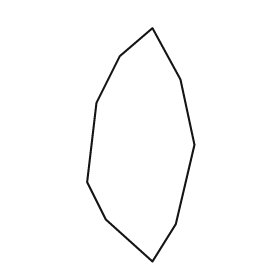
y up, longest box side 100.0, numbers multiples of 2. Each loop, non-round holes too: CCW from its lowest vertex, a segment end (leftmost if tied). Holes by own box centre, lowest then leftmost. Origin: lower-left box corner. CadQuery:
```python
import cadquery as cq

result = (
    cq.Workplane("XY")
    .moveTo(28.0, 0.0)
    .lineTo(38.0, 16.0)
    .lineTo(46.0, 50.0)
    .lineTo(40.0, 78.0)
    .lineTo(28.0, 100.0)
    .lineTo(14.0, 88.0)
    .lineTo(4.0, 68.0)
    .lineTo(0.0, 34.0)
    .lineTo(8.0, 18.0)
    .close()
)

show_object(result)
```